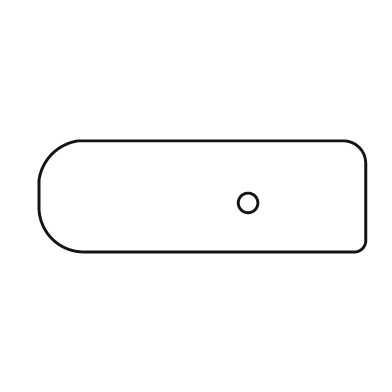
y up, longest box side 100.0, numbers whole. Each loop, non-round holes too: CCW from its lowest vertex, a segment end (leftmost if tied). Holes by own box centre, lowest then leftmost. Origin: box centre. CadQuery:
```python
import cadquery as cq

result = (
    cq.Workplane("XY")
    .moveTo(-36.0, -17.0)
    .lineTo(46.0, -17.0)
    .threePointArc((49.0, -16.0), (50.0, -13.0))
    .lineTo(50.0, 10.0)
    .threePointArc((48.0, 15.0), (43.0, 17.0))
    .lineTo(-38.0, 17.0)
    .threePointArc((-46.0, 13.0), (-50.0, 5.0))
    .lineTo(-50.0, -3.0)
    .threePointArc((-46.0, -13.0), (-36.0, -17.0))
    .close()
    .moveTo(14.0, -2.0)
    .circle(3.0)
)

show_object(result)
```